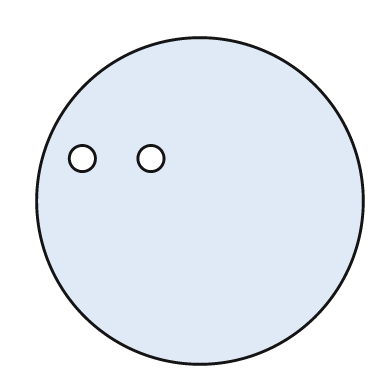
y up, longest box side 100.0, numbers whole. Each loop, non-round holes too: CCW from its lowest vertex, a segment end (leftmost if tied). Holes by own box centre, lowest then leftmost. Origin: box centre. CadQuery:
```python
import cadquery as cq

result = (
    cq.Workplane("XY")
    .moveTo(0.0, 0.0)
    .circle(50.0)
    .moveTo(-36.0, 13.0)
    .circle(4.0)
    .moveTo(-15.0, 13.0)
    .circle(4.0)
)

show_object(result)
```